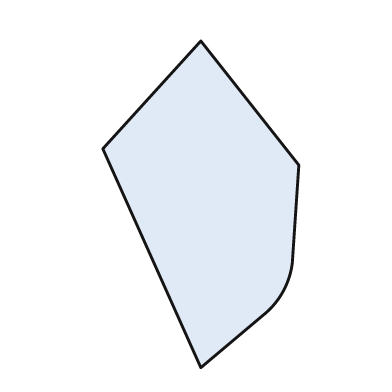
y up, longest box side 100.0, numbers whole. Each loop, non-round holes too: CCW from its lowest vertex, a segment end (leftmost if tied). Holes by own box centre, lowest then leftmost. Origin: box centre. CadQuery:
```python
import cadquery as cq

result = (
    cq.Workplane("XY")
    .moveTo(0.0, -50.0)
    .lineTo(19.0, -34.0)
    .threePointArc((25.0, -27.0), (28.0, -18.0))
    .lineTo(30.0, 12.0)
    .lineTo(0.0, 50.0)
    .lineTo(-30.0, 17.0)
    .close()
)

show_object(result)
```